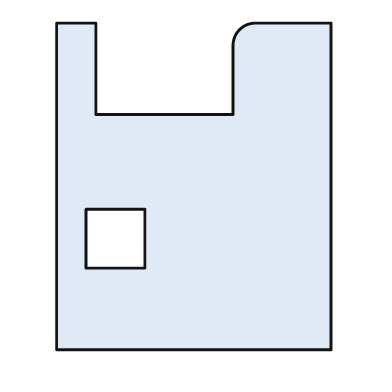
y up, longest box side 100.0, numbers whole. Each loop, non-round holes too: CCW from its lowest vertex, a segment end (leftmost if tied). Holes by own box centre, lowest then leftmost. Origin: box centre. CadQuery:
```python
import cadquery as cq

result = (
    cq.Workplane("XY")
    .moveTo(-42.0, -50.0)
    .lineTo(42.0, -50.0)
    .lineTo(42.0, 50.0)
    .lineTo(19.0, 50.0)
    .threePointArc((14.0, 48.0), (12.0, 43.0))
    .lineTo(12.0, 22.0)
    .lineTo(-30.0, 22.0)
    .lineTo(-30.0, 50.0)
    .lineTo(-42.0, 50.0)
    .close()
    .moveTo(-33.0, -25.0)
    .lineTo(-15.0, -25.0)
    .lineTo(-15.0, -7.0)
    .lineTo(-33.0, -7.0)
    .close()
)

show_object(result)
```